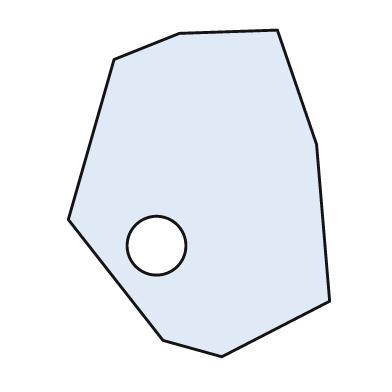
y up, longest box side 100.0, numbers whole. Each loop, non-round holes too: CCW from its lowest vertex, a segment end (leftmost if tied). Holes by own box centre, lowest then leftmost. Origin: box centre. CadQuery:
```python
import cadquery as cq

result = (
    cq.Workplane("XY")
    .moveTo(7.0, -50.0)
    .lineTo(40.0, -33.0)
    .lineTo(36.0, 15.0)
    .lineTo(24.0, 50.0)
    .lineTo(-6.0, 49.0)
    .lineTo(-26.0, 41.0)
    .lineTo(-40.0, -8.0)
    .lineTo(-11.0, -45.0)
    .close()
    .moveTo(-13.0, -16.0)
    .circle(9.0)
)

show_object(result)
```